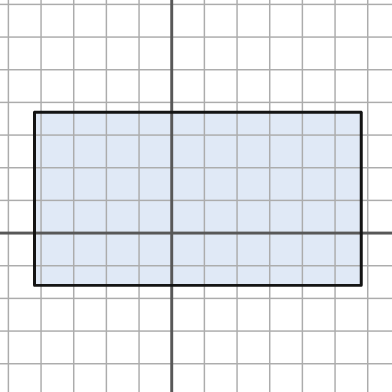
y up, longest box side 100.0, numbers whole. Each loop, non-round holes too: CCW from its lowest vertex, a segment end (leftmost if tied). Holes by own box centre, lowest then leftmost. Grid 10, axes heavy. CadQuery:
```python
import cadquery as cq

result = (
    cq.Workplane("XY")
    .moveTo(-42.0, -16.0)
    .lineTo(58.0, -16.0)
    .lineTo(58.0, 37.0)
    .lineTo(-42.0, 37.0)
    .close()
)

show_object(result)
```